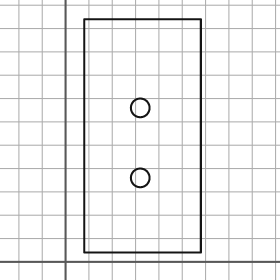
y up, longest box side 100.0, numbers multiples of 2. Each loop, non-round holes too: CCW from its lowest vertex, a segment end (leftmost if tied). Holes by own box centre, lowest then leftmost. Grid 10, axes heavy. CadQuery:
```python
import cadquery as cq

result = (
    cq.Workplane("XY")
    .moveTo(8.0, 4.0)
    .lineTo(58.0, 4.0)
    .lineTo(58.0, 104.0)
    .lineTo(8.0, 104.0)
    .close()
    .moveTo(32.0, 36.0)
    .circle(4.0)
    .moveTo(32.0, 66.0)
    .circle(4.0)
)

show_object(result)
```